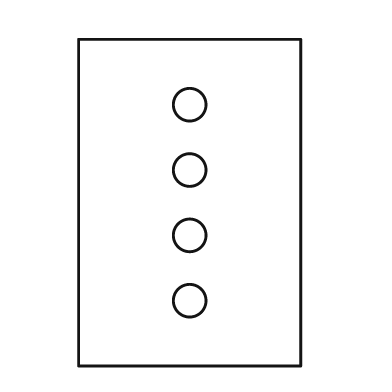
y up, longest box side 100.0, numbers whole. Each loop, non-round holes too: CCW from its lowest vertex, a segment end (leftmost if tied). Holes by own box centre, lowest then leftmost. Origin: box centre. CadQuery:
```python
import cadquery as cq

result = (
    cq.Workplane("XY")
    .moveTo(-34.0, -50.0)
    .lineTo(34.0, -50.0)
    .lineTo(34.0, 50.0)
    .lineTo(-34.0, 50.0)
    .close()
    .moveTo(0.0, -30.0)
    .circle(5.0)
    .moveTo(0.0, -10.0)
    .circle(5.0)
    .moveTo(0.0, 10.0)
    .circle(5.0)
    .moveTo(0.0, 30.0)
    .circle(5.0)
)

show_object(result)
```